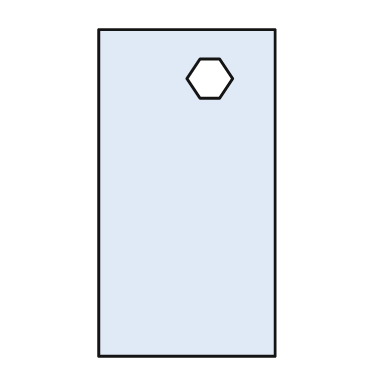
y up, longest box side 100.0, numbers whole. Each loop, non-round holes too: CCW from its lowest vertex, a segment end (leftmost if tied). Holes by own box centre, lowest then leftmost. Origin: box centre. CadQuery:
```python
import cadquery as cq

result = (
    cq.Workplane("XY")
    .moveTo(-27.0, -50.0)
    .lineTo(27.0, -50.0)
    .lineTo(27.0, 50.0)
    .lineTo(-27.0, 50.0)
    .close()
    .moveTo(4.0, 29.0)
    .lineTo(10.0, 29.0)
    .lineTo(14.0, 35.0)
    .lineTo(10.0, 41.0)
    .lineTo(4.0, 41.0)
    .lineTo(0.0, 35.0)
    .close()
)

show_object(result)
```